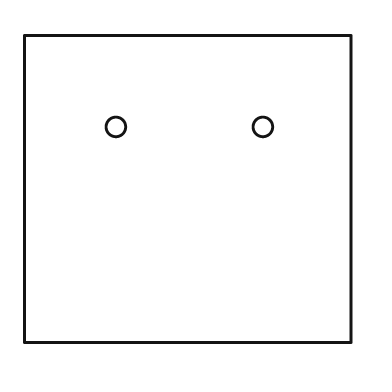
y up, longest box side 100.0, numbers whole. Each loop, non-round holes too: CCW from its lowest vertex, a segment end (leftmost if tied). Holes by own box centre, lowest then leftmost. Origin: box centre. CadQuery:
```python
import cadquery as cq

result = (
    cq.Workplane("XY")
    .moveTo(-50.0, -47.0)
    .lineTo(50.0, -47.0)
    .lineTo(50.0, 47.0)
    .lineTo(-50.0, 47.0)
    .close()
    .moveTo(-22.0, 19.0)
    .circle(3.0)
    .moveTo(23.0, 19.0)
    .circle(3.0)
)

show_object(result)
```